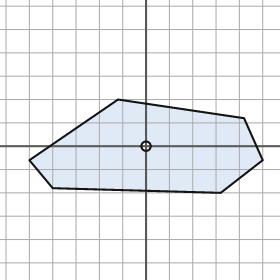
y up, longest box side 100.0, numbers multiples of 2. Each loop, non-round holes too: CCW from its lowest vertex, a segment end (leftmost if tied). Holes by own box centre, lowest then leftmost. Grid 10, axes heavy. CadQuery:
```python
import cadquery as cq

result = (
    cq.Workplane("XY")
    .moveTo(32.0, -20.0)
    .lineTo(50.0, -6.0)
    .lineTo(42.0, 12.0)
    .lineTo(-12.0, 20.0)
    .lineTo(-50.0, -6.0)
    .lineTo(-40.0, -18.0)
    .close()
    .moveTo(0.0, 0.0)
    .circle(2.0)
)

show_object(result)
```